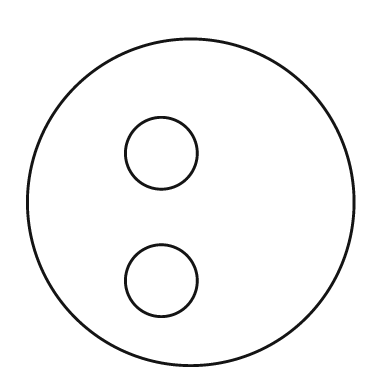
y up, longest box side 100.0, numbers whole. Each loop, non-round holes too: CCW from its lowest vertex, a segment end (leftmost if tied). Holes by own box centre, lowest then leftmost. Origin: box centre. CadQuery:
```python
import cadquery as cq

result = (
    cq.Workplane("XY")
    .moveTo(0.0, 0.0)
    .circle(50.0)
    .moveTo(-9.0, -24.0)
    .circle(11.0)
    .moveTo(-9.0, 15.0)
    .circle(11.0)
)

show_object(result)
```